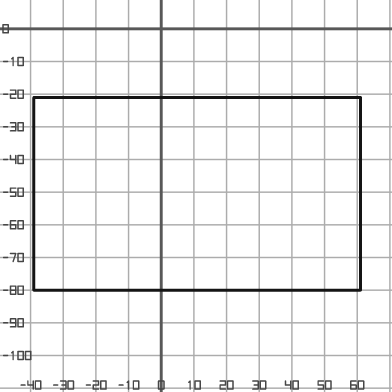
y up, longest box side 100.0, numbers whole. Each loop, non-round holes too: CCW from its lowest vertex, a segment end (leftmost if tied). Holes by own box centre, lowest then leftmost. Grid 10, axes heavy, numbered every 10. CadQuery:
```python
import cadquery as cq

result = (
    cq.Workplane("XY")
    .moveTo(-39.0, -80.0)
    .lineTo(61.0, -80.0)
    .lineTo(61.0, -21.0)
    .lineTo(-39.0, -21.0)
    .close()
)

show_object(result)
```